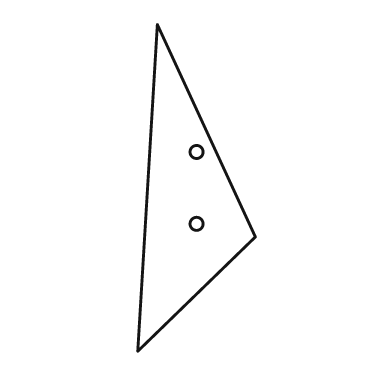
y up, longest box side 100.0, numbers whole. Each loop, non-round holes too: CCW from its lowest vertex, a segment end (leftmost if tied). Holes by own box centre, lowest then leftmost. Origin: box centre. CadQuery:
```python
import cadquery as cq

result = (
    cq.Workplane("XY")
    .moveTo(-18.0, -50.0)
    .lineTo(18.0, -15.0)
    .lineTo(-12.0, 50.0)
    .close()
    .moveTo(0.0, -11.0)
    .circle(2.0)
    .moveTo(0.0, 11.0)
    .circle(2.0)
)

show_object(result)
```